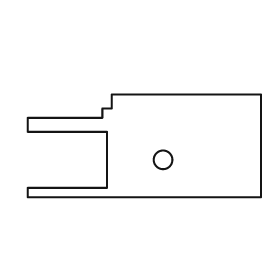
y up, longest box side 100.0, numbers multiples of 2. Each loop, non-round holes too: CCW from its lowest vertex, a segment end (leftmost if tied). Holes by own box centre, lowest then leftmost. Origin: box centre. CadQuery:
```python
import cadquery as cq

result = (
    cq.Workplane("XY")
    .moveTo(-50.0, -22.0)
    .lineTo(50.0, -22.0)
    .lineTo(50.0, 22.0)
    .lineTo(-14.0, 22.0)
    .lineTo(-14.0, 16.0)
    .lineTo(-18.0, 16.0)
    .lineTo(-18.0, 12.0)
    .lineTo(-50.0, 12.0)
    .lineTo(-50.0, 6.0)
    .lineTo(-16.0, 6.0)
    .lineTo(-16.0, -18.0)
    .lineTo(-50.0, -18.0)
    .close()
    .moveTo(8.0, -6.0)
    .circle(4.0)
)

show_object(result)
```